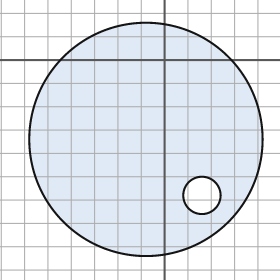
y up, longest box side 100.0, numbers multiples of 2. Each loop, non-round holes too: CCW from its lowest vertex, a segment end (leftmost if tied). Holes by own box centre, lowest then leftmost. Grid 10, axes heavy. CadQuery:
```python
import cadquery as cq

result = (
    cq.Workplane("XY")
    .moveTo(-8.0, -34.0)
    .circle(50.0)
    .moveTo(16.0, -58.0)
    .circle(8.0)
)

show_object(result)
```